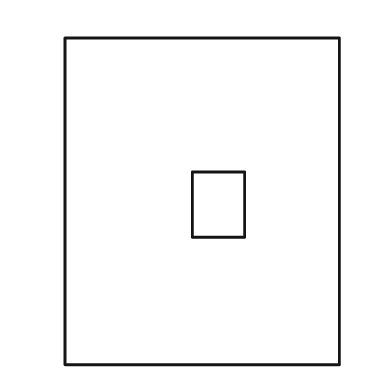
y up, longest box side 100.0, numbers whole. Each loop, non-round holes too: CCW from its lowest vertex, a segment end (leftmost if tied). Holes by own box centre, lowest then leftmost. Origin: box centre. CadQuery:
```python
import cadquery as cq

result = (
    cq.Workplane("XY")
    .moveTo(-42.0, -50.0)
    .lineTo(42.0, -50.0)
    .lineTo(42.0, 50.0)
    .lineTo(-42.0, 50.0)
    .close()
    .moveTo(-3.0, -11.0)
    .lineTo(13.0, -11.0)
    .lineTo(13.0, 9.0)
    .lineTo(-3.0, 9.0)
    .close()
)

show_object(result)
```